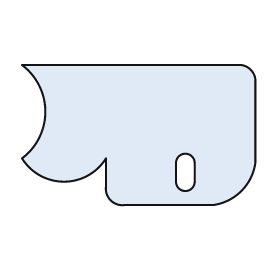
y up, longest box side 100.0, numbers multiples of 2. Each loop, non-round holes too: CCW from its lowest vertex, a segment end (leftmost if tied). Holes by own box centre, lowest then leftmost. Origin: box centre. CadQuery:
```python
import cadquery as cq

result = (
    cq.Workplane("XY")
    .moveTo(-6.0, -30.0)
    .lineTo(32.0, -30.0)
    .threePointArc((44.0, -24.0), (50.0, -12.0))
    .lineTo(50.0, 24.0)
    .threePointArc((48.0, 28.0), (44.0, 30.0))
    .lineTo(-50.0, 30.0)
    .threePointArc((-40.0, 10.0), (-50.0, -10.0))
    .threePointArc((-32.0, -20.0), (-14.0, -10.0))
    .lineTo(-14.0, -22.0)
    .threePointArc((-12.0, -28.0), (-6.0, -30.0))
    .close()
    .moveTo(16.0, -20.0)
    .threePointArc((20.0, -24.0), (24.0, -20.0))
    .lineTo(24.0, -12.0)
    .threePointArc((20.0, -8.0), (16.0, -12.0))
    .close()
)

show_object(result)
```